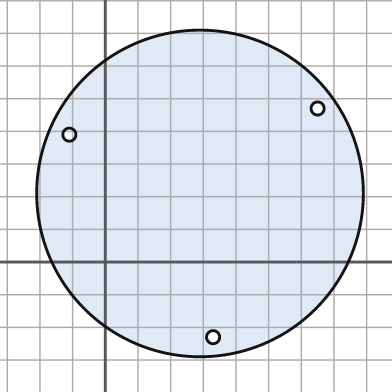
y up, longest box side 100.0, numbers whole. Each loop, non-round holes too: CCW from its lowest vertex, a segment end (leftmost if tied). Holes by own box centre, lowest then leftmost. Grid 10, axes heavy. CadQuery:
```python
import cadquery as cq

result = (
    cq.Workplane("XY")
    .moveTo(29.0, 21.0)
    .circle(50.0)
    .moveTo(33.0, -23.0)
    .circle(2.0)
    .moveTo(-11.0, 39.0)
    .circle(2.0)
    .moveTo(65.0, 47.0)
    .circle(2.0)
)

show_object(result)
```